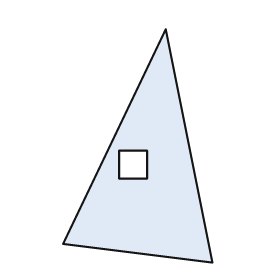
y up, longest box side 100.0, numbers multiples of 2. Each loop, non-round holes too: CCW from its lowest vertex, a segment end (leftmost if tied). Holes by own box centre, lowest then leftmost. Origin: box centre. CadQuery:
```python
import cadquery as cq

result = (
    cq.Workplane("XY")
    .moveTo(32.0, -50.0)
    .lineTo(12.0, 50.0)
    .lineTo(-32.0, -42.0)
    .close()
    .moveTo(-8.0, -14.0)
    .lineTo(4.0, -14.0)
    .lineTo(4.0, -2.0)
    .lineTo(-8.0, -2.0)
    .close()
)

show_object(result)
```